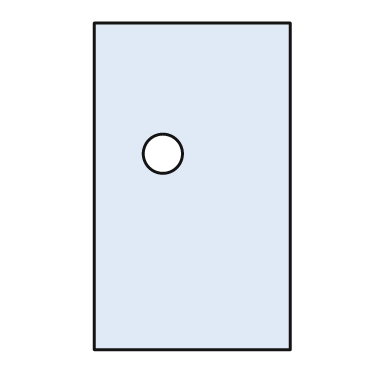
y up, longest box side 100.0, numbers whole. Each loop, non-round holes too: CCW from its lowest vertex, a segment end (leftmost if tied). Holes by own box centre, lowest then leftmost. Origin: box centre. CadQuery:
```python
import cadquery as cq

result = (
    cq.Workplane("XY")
    .moveTo(-30.0, -50.0)
    .lineTo(30.0, -50.0)
    .lineTo(30.0, 50.0)
    .lineTo(-30.0, 50.0)
    .close()
    .moveTo(-9.0, 10.0)
    .circle(6.0)
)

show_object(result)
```